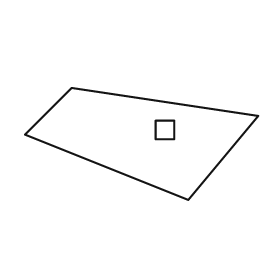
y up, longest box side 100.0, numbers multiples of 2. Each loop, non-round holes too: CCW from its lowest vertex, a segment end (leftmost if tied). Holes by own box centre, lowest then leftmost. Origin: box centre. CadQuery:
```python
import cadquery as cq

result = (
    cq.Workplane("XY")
    .moveTo(20.0, -24.0)
    .lineTo(50.0, 12.0)
    .lineTo(-30.0, 24.0)
    .lineTo(-50.0, 4.0)
    .close()
    .moveTo(6.0, 2.0)
    .lineTo(14.0, 2.0)
    .lineTo(14.0, 10.0)
    .lineTo(6.0, 10.0)
    .close()
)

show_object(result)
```